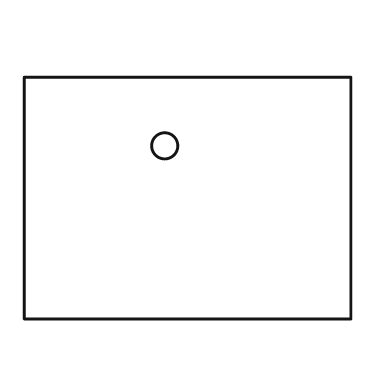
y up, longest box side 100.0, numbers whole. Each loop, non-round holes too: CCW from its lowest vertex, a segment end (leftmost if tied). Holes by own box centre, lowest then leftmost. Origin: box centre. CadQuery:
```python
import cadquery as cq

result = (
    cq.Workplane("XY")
    .moveTo(-50.0, -37.0)
    .lineTo(50.0, -37.0)
    .lineTo(50.0, 37.0)
    .lineTo(-50.0, 37.0)
    .close()
    .moveTo(-7.0, 16.0)
    .circle(4.0)
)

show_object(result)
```